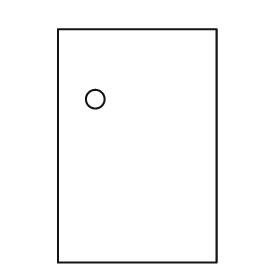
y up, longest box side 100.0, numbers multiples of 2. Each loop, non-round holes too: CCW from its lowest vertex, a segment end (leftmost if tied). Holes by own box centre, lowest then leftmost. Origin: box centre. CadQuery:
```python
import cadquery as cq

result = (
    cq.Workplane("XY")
    .moveTo(-34.0, -50.0)
    .lineTo(34.0, -50.0)
    .lineTo(34.0, 50.0)
    .lineTo(-34.0, 50.0)
    .close()
    .moveTo(-18.0, 20.0)
    .circle(4.0)
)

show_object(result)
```